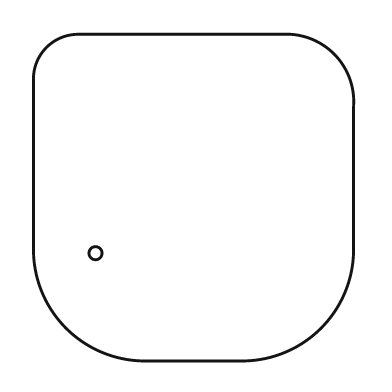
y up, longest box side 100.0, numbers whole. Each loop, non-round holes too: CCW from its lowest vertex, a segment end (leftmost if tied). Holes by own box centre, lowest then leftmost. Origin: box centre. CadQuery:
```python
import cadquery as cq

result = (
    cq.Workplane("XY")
    .moveTo(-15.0, -50.0)
    .lineTo(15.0, -50.0)
    .threePointArc((39.0, -40.0), (49.0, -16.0))
    .lineTo(49.0, 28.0)
    .threePointArc((43.0, 44.0), (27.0, 50.0))
    .lineTo(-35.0, 50.0)
    .threePointArc((-45.0, 46.0), (-49.0, 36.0))
    .lineTo(-49.0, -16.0)
    .threePointArc((-39.0, -40.0), (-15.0, -50.0))
    .close()
    .moveTo(-30.0, -17.0)
    .circle(2.0)
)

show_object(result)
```